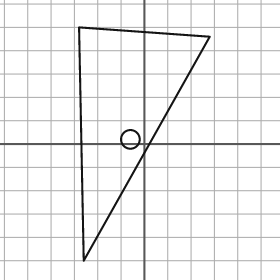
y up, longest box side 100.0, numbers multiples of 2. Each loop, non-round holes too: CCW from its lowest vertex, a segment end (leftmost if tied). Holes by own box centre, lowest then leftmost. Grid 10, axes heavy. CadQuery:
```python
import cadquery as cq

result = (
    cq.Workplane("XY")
    .moveTo(-26.0, -50.0)
    .lineTo(28.0, 46.0)
    .lineTo(-28.0, 50.0)
    .close()
    .moveTo(-6.0, 2.0)
    .circle(4.0)
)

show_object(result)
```